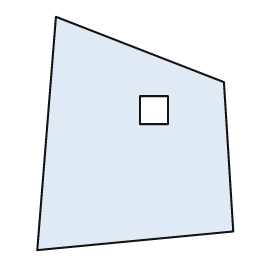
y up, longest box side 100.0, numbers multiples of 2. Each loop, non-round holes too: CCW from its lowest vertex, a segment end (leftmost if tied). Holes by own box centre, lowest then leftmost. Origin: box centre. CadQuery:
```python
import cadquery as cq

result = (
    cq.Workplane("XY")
    .moveTo(-42.0, -50.0)
    .lineTo(42.0, -42.0)
    .lineTo(38.0, 22.0)
    .lineTo(-34.0, 50.0)
    .close()
    .moveTo(2.0, 4.0)
    .lineTo(14.0, 4.0)
    .lineTo(14.0, 16.0)
    .lineTo(2.0, 16.0)
    .close()
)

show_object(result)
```